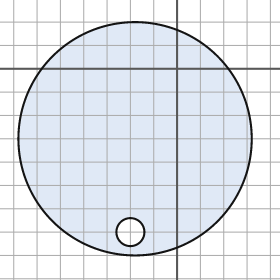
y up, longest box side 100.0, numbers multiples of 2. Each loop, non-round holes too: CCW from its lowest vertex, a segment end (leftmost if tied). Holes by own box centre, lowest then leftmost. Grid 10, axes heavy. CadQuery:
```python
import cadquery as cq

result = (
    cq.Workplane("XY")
    .moveTo(-18.0, -30.0)
    .circle(50.0)
    .moveTo(-20.0, -70.0)
    .circle(6.0)
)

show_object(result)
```